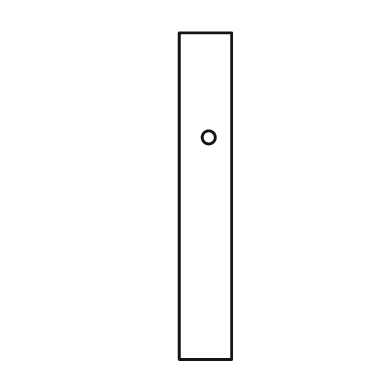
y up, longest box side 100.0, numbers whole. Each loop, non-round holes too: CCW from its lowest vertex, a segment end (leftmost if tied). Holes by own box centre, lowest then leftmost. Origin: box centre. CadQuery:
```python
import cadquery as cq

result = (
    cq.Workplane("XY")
    .moveTo(-8.0, -50.0)
    .lineTo(8.0, -50.0)
    .lineTo(8.0, 50.0)
    .lineTo(-8.0, 50.0)
    .close()
    .moveTo(1.0, 18.0)
    .circle(2.0)
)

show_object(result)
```